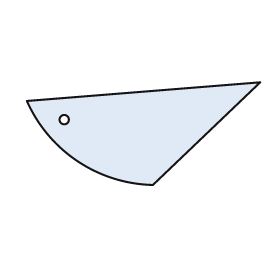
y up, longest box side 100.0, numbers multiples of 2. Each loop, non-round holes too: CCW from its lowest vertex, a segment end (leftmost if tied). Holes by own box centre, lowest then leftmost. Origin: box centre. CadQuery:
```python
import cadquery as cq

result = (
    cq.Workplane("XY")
    .moveTo(4.0, -22.0)
    .lineTo(50.0, 22.0)
    .lineTo(-50.0, 14.0)
    .threePointArc((-28.0, -12.0), (4.0, -22.0))
    .close()
    .moveTo(-34.0, 6.0)
    .circle(2.0)
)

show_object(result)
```